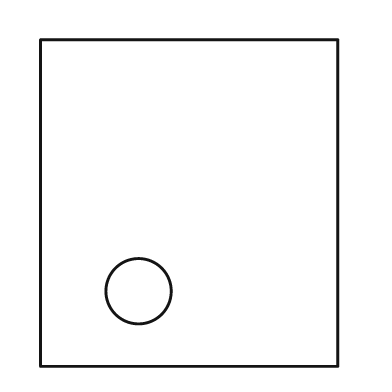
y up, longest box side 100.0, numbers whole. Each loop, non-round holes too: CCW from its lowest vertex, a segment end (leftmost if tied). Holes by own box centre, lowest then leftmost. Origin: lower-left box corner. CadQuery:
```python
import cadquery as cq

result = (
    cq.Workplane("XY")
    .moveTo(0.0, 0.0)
    .lineTo(91.0, 0.0)
    .lineTo(91.0, 100.0)
    .lineTo(0.0, 100.0)
    .close()
    .moveTo(30.0, 23.0)
    .circle(10.0)
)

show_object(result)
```